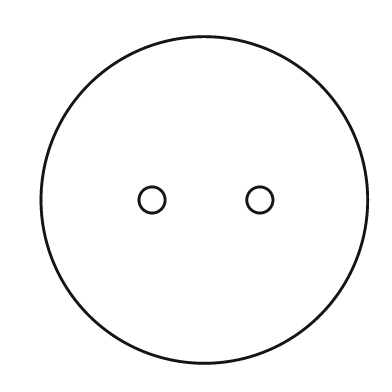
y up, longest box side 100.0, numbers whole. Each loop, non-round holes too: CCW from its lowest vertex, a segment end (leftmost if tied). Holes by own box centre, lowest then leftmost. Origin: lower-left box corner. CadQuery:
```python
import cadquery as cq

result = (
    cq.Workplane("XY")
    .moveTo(50.0, 50.0)
    .circle(50.0)
    .moveTo(34.0, 50.0)
    .circle(4.0)
    .moveTo(67.0, 50.0)
    .circle(4.0)
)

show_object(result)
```